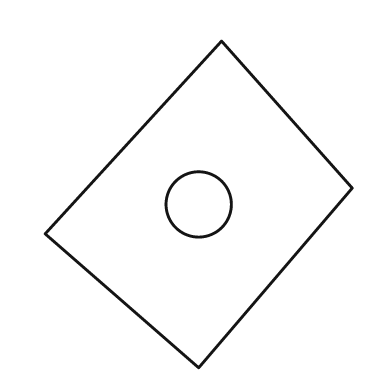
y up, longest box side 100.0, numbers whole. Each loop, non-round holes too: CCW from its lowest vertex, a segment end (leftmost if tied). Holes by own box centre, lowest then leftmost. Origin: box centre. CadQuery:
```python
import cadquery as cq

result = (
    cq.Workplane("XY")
    .moveTo(0.0, -50.0)
    .lineTo(47.0, 5.0)
    .lineTo(7.0, 50.0)
    .lineTo(-47.0, -9.0)
    .close()
    .moveTo(0.0, 0.0)
    .circle(10.0)
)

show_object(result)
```